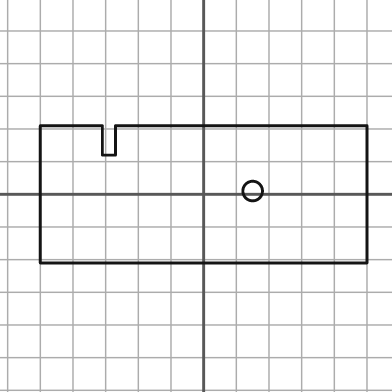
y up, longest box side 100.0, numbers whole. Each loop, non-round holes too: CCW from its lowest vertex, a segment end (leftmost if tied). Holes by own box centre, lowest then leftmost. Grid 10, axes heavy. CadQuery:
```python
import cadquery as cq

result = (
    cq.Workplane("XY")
    .moveTo(-50.0, -21.0)
    .lineTo(50.0, -21.0)
    .lineTo(50.0, 21.0)
    .lineTo(-27.0, 21.0)
    .lineTo(-27.0, 12.0)
    .lineTo(-31.0, 12.0)
    .lineTo(-31.0, 21.0)
    .lineTo(-50.0, 21.0)
    .close()
    .moveTo(15.0, 1.0)
    .circle(3.0)
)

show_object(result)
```